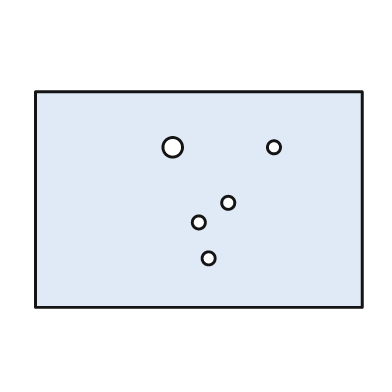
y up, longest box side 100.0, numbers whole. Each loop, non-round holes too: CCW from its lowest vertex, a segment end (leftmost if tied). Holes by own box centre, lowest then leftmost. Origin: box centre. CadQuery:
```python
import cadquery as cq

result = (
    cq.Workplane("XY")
    .moveTo(-50.0, -33.0)
    .lineTo(50.0, -33.0)
    .lineTo(50.0, 33.0)
    .lineTo(-50.0, 33.0)
    .close()
    .moveTo(3.0, -18.0)
    .circle(2.0)
    .moveTo(0.0, -7.0)
    .circle(2.0)
    .moveTo(9.0, -1.0)
    .circle(2.0)
    .moveTo(-8.0, 16.0)
    .circle(3.0)
    .moveTo(23.0, 16.0)
    .circle(2.0)
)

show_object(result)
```